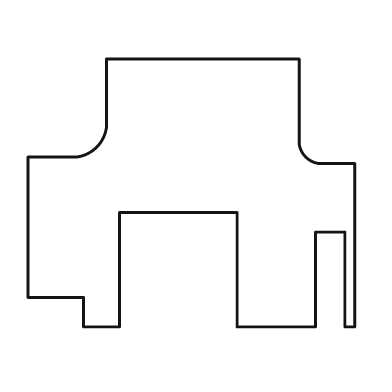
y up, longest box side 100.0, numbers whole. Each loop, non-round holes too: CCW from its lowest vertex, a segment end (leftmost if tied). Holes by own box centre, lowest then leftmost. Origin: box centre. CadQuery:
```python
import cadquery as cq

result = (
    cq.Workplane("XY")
    .moveTo(-33.0, -41.0)
    .lineTo(-22.0, -41.0)
    .lineTo(-22.0, -6.0)
    .lineTo(14.0, -6.0)
    .lineTo(14.0, -41.0)
    .lineTo(38.0, -41.0)
    .lineTo(38.0, -12.0)
    .lineTo(47.0, -12.0)
    .lineTo(47.0, -41.0)
    .lineTo(50.0, -41.0)
    .lineTo(50.0, 9.0)
    .lineTo(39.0, 9.0)
    .threePointArc((35.0, 11.0), (33.0, 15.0))
    .lineTo(33.0, 41.0)
    .lineTo(-26.0, 41.0)
    .lineTo(-26.0, 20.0)
    .threePointArc((-29.0, 14.0), (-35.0, 11.0))
    .lineTo(-50.0, 11.0)
    .lineTo(-50.0, -32.0)
    .lineTo(-33.0, -32.0)
    .close()
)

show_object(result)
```